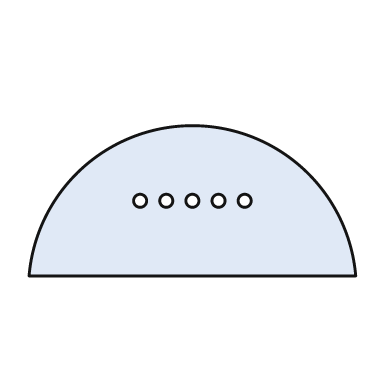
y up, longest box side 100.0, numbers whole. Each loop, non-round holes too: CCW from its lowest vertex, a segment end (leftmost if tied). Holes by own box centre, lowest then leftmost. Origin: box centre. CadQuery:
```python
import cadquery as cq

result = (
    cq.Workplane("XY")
    .moveTo(-50.0, -23.0)
    .lineTo(50.0, -23.0)
    .threePointArc((0.0, 23.0), (-50.0, -23.0))
    .close()
    .moveTo(-16.0, 0.0)
    .circle(2.0)
    .moveTo(-8.0, 0.0)
    .circle(2.0)
    .moveTo(0.0, 0.0)
    .circle(2.0)
    .moveTo(8.0, 0.0)
    .circle(2.0)
    .moveTo(16.0, 0.0)
    .circle(2.0)
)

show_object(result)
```